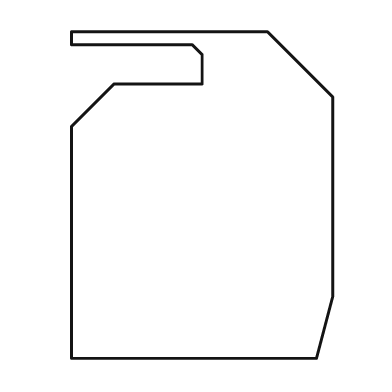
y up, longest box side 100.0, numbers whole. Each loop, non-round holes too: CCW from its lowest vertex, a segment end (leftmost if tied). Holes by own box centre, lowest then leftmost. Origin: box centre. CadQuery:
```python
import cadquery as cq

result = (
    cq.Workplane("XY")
    .moveTo(-40.0, -50.0)
    .lineTo(35.0, -50.0)
    .lineTo(40.0, -31.0)
    .lineTo(40.0, 30.0)
    .lineTo(20.0, 50.0)
    .lineTo(-40.0, 50.0)
    .lineTo(-40.0, 46.0)
    .lineTo(-3.0, 46.0)
    .lineTo(0.0, 43.0)
    .lineTo(0.0, 34.0)
    .lineTo(-27.0, 34.0)
    .lineTo(-40.0, 21.0)
    .close()
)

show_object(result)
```